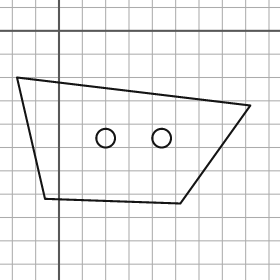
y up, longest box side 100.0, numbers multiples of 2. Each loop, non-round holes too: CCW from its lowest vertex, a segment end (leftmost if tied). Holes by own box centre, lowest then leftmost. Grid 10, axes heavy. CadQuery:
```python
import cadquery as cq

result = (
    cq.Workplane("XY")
    .moveTo(52.0, -74.0)
    .lineTo(82.0, -32.0)
    .lineTo(-18.0, -20.0)
    .lineTo(-6.0, -72.0)
    .close()
    .moveTo(20.0, -46.0)
    .circle(4.0)
    .moveTo(44.0, -46.0)
    .circle(4.0)
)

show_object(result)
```